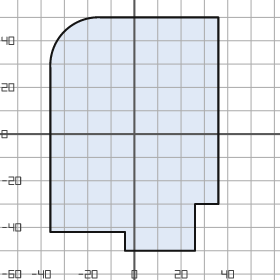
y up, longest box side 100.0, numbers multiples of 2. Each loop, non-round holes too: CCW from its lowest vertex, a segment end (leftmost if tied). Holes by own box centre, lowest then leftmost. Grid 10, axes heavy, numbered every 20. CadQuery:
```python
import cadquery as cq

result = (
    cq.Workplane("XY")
    .moveTo(-4.0, -50.0)
    .lineTo(26.0, -50.0)
    .lineTo(26.0, -30.0)
    .lineTo(36.0, -30.0)
    .lineTo(36.0, 50.0)
    .lineTo(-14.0, 50.0)
    .threePointArc((-30.0, 44.0), (-36.0, 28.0))
    .lineTo(-36.0, -42.0)
    .lineTo(-4.0, -42.0)
    .close()
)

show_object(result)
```